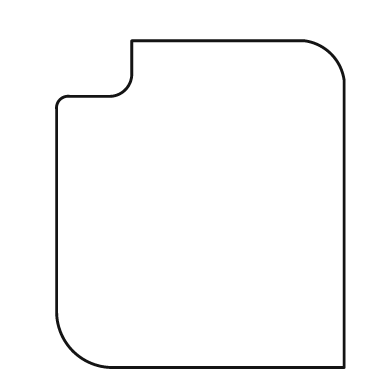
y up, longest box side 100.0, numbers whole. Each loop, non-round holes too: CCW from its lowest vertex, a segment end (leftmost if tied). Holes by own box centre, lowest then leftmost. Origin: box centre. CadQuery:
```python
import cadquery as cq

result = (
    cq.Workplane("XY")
    .moveTo(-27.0, -50.0)
    .lineTo(44.0, -50.0)
    .lineTo(44.0, 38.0)
    .threePointArc((40.0, 46.0), (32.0, 50.0))
    .lineTo(-21.0, 50.0)
    .lineTo(-21.0, 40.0)
    .threePointArc((-23.0, 35.0), (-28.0, 33.0))
    .lineTo(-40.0, 33.0)
    .threePointArc((-43.0, 32.0), (-44.0, 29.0))
    .lineTo(-44.0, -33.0)
    .threePointArc((-39.0, -45.0), (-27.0, -50.0))
    .close()
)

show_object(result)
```